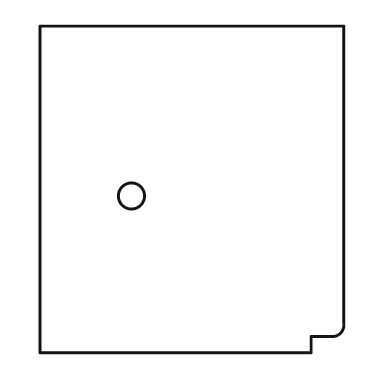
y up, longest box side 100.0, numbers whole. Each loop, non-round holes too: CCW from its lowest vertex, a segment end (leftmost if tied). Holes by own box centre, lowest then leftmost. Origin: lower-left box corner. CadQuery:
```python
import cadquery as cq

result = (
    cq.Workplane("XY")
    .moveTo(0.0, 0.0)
    .lineTo(83.0, 0.0)
    .lineTo(83.0, 5.0)
    .lineTo(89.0, 5.0)
    .threePointArc((92.0, 6.0), (93.0, 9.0))
    .lineTo(93.0, 100.0)
    .lineTo(0.0, 100.0)
    .close()
    .moveTo(28.0, 48.0)
    .circle(4.0)
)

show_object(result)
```